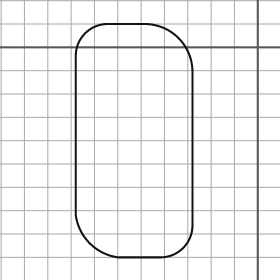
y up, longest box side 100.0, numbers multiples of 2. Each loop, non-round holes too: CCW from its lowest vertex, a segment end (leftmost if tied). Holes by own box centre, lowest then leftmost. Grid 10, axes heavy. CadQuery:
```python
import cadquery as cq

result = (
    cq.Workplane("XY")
    .moveTo(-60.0, -90.0)
    .lineTo(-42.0, -90.0)
    .threePointArc((-32.0, -86.0), (-28.0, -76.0))
    .lineTo(-28.0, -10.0)
    .threePointArc((-34.0, 4.0), (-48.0, 10.0))
    .lineTo(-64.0, 10.0)
    .threePointArc((-74.0, 6.0), (-78.0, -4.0))
    .lineTo(-78.0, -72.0)
    .threePointArc((-72.0, -84.0), (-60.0, -90.0))
    .close()
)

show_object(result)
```